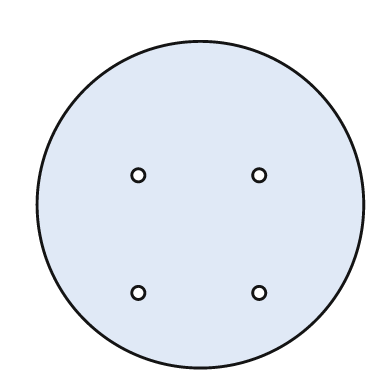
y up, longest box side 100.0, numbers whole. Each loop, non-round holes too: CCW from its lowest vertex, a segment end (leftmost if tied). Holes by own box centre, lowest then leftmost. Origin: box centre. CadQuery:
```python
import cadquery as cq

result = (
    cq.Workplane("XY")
    .moveTo(0.0, 0.0)
    .circle(50.0)
    .moveTo(-19.0, -27.0)
    .circle(2.0)
    .moveTo(18.0, -27.0)
    .circle(2.0)
    .moveTo(-19.0, 9.0)
    .circle(2.0)
    .moveTo(18.0, 9.0)
    .circle(2.0)
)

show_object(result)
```